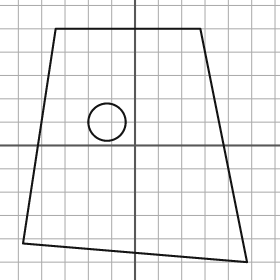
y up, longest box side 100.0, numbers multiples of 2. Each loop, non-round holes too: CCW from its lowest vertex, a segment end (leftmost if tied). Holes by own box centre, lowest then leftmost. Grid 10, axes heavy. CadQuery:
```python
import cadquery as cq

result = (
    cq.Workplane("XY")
    .moveTo(48.0, -50.0)
    .lineTo(28.0, 50.0)
    .lineTo(-34.0, 50.0)
    .lineTo(-48.0, -42.0)
    .close()
    .moveTo(-12.0, 10.0)
    .circle(8.0)
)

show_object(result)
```